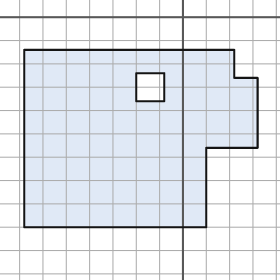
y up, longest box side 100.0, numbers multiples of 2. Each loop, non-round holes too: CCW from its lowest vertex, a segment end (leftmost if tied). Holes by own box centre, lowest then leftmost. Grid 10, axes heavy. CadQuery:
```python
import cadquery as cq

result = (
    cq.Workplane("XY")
    .moveTo(-68.0, -90.0)
    .lineTo(10.0, -90.0)
    .lineTo(10.0, -56.0)
    .lineTo(32.0, -56.0)
    .lineTo(32.0, -26.0)
    .lineTo(22.0, -26.0)
    .lineTo(22.0, -14.0)
    .lineTo(-68.0, -14.0)
    .close()
    .moveTo(-20.0, -36.0)
    .lineTo(-8.0, -36.0)
    .lineTo(-8.0, -24.0)
    .lineTo(-20.0, -24.0)
    .close()
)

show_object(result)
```